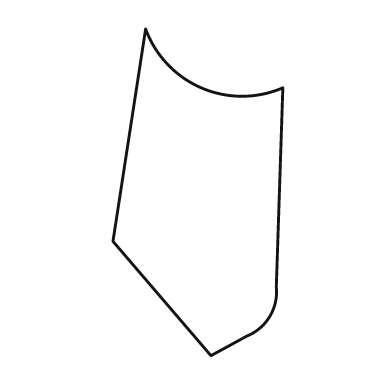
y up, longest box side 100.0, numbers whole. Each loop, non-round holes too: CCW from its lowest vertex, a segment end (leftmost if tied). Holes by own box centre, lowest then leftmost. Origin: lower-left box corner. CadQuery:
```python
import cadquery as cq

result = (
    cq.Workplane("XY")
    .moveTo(30.0, 0.0)
    .lineTo(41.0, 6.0)
    .threePointArc((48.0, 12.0), (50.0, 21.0))
    .lineTo(52.0, 82.0)
    .threePointArc((27.0, 82.0), (10.0, 100.0))
    .lineTo(0.0, 35.0)
    .close()
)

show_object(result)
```